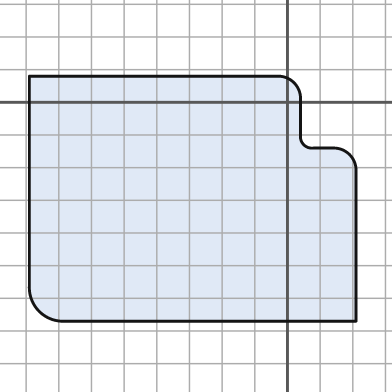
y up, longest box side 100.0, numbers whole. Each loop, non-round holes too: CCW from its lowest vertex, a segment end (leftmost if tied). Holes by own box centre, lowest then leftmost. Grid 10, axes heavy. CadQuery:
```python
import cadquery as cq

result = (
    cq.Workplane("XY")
    .moveTo(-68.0, -67.0)
    .lineTo(21.0, -67.0)
    .lineTo(21.0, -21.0)
    .threePointArc((19.0, -16.0), (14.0, -14.0))
    .lineTo(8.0, -14.0)
    .threePointArc((5.0, -13.0), (4.0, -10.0))
    .lineTo(4.0, 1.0)
    .threePointArc((2.0, 6.0), (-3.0, 8.0))
    .lineTo(-79.0, 8.0)
    .lineTo(-79.0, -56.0)
    .threePointArc((-76.0, -64.0), (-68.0, -67.0))
    .close()
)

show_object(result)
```